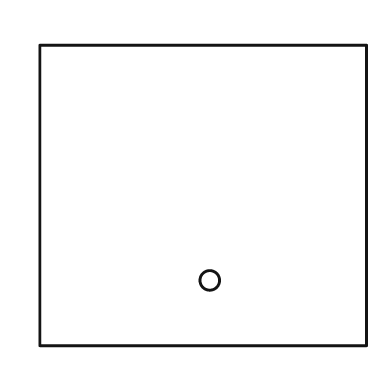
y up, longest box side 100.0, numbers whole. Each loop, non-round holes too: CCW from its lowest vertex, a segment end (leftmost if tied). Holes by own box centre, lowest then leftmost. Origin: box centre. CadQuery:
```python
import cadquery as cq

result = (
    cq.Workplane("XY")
    .moveTo(-50.0, -46.0)
    .lineTo(50.0, -46.0)
    .lineTo(50.0, 46.0)
    .lineTo(-50.0, 46.0)
    .close()
    .moveTo(2.0, -26.0)
    .circle(3.0)
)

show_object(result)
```